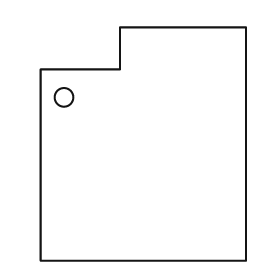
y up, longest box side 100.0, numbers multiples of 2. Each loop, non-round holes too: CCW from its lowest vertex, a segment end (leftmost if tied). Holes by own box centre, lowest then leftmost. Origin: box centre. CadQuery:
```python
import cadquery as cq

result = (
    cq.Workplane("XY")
    .moveTo(-44.0, -50.0)
    .lineTo(44.0, -50.0)
    .lineTo(44.0, 50.0)
    .lineTo(-10.0, 50.0)
    .lineTo(-10.0, 32.0)
    .lineTo(-44.0, 32.0)
    .close()
    .moveTo(-34.0, 20.0)
    .circle(4.0)
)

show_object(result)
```